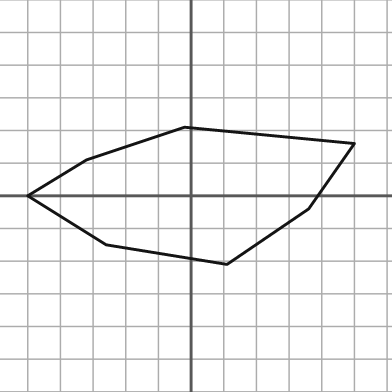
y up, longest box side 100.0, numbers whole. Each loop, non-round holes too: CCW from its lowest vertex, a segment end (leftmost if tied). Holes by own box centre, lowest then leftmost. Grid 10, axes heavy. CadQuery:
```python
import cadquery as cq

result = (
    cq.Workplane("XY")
    .moveTo(11.0, -21.0)
    .lineTo(36.0, -4.0)
    .lineTo(50.0, 16.0)
    .lineTo(-2.0, 21.0)
    .lineTo(-32.0, 11.0)
    .lineTo(-50.0, 0.0)
    .lineTo(-26.0, -15.0)
    .close()
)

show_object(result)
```